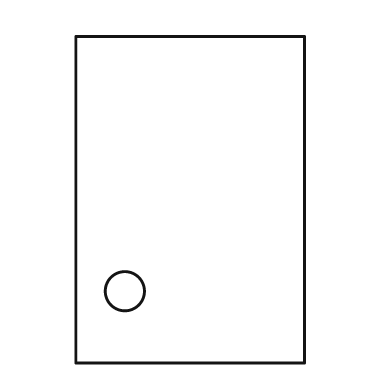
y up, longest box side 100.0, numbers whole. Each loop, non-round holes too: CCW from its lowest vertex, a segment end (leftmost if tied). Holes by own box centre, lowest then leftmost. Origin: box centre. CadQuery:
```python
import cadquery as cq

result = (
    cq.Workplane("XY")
    .moveTo(-35.0, -50.0)
    .lineTo(35.0, -50.0)
    .lineTo(35.0, 50.0)
    .lineTo(-35.0, 50.0)
    .close()
    .moveTo(-20.0, -28.0)
    .circle(6.0)
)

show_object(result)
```